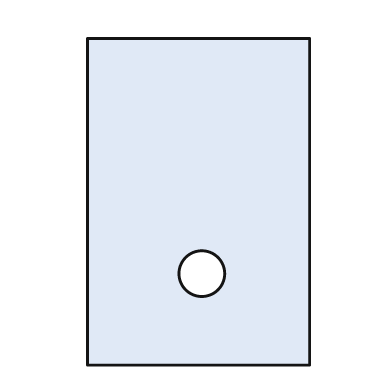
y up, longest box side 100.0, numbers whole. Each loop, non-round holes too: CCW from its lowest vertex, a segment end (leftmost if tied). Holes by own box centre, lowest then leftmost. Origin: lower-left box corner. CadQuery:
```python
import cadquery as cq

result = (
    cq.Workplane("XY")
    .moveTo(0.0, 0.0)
    .lineTo(68.0, 0.0)
    .lineTo(68.0, 100.0)
    .lineTo(0.0, 100.0)
    .close()
    .moveTo(35.0, 28.0)
    .circle(7.0)
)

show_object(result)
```